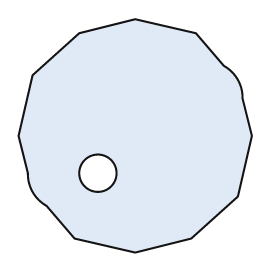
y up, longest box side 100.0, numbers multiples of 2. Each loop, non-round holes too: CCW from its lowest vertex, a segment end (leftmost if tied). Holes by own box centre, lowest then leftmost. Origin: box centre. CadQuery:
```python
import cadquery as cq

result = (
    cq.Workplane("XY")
    .moveTo(0.0, -50.0)
    .lineTo(24.0, -44.0)
    .lineTo(44.0, -26.0)
    .lineTo(50.0, 0.0)
    .lineTo(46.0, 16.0)
    .threePointArc((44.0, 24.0), (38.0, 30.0))
    .lineTo(26.0, 44.0)
    .lineTo(0.0, 50.0)
    .lineTo(-24.0, 44.0)
    .lineTo(-44.0, 26.0)
    .lineTo(-50.0, 0.0)
    .lineTo(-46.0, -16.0)
    .threePointArc((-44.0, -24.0), (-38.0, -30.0))
    .lineTo(-26.0, -44.0)
    .close()
    .moveTo(-16.0, -16.0)
    .circle(8.0)
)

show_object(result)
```